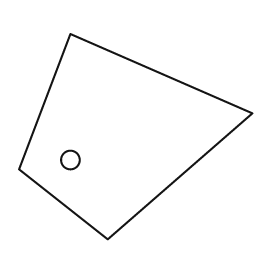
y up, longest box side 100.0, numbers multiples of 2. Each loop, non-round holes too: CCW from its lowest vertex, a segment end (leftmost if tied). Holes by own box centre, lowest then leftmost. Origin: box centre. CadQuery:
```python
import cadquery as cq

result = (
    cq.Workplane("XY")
    .moveTo(-12.0, -44.0)
    .lineTo(50.0, 10.0)
    .lineTo(-28.0, 44.0)
    .lineTo(-50.0, -14.0)
    .close()
    .moveTo(-28.0, -10.0)
    .circle(4.0)
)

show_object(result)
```